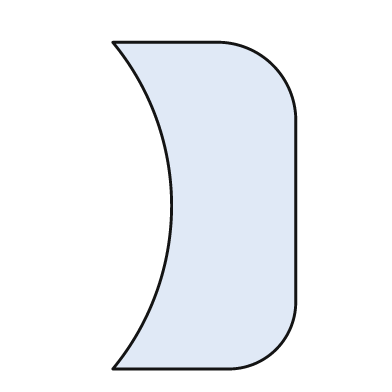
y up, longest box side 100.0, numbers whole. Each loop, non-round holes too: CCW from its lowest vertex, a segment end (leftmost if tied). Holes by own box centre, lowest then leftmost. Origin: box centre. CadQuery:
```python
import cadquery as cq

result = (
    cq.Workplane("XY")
    .moveTo(-28.0, -50.0)
    .lineTo(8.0, -50.0)
    .threePointArc((22.0, -44.0), (28.0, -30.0))
    .lineTo(28.0, 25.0)
    .threePointArc((21.0, 43.0), (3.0, 50.0))
    .lineTo(-28.0, 50.0)
    .threePointArc((-10.0, 0.0), (-28.0, -50.0))
    .close()
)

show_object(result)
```